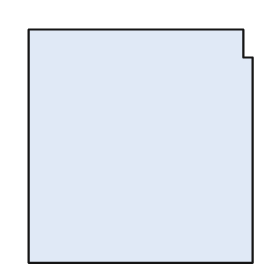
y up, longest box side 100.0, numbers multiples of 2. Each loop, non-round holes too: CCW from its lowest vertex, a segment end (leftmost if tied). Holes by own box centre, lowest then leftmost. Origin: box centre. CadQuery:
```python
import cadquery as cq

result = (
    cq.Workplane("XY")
    .moveTo(-48.0, -50.0)
    .lineTo(48.0, -50.0)
    .lineTo(48.0, 38.0)
    .lineTo(44.0, 38.0)
    .lineTo(44.0, 50.0)
    .lineTo(-48.0, 50.0)
    .close()
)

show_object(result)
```